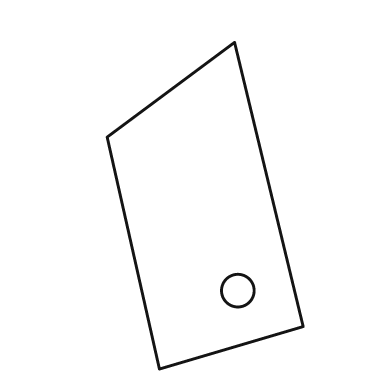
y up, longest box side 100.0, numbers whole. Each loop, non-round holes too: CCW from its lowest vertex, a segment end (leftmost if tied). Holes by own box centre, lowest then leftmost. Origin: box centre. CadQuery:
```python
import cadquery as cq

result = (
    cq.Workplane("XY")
    .moveTo(-14.0, -50.0)
    .lineTo(30.0, -37.0)
    .lineTo(9.0, 50.0)
    .lineTo(-30.0, 21.0)
    .close()
    .moveTo(10.0, -26.0)
    .circle(5.0)
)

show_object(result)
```